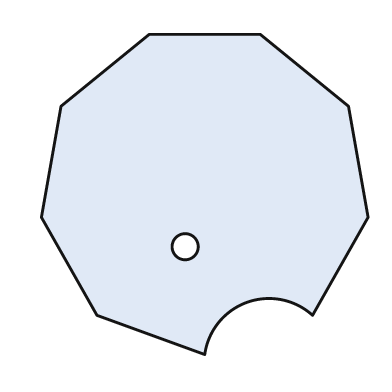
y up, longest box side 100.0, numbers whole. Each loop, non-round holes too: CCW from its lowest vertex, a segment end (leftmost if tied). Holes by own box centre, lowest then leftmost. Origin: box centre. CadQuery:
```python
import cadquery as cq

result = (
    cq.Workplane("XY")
    .moveTo(0.0, -49.0)
    .threePointArc((13.0, -33.0), (33.0, -37.0))
    .lineTo(50.0, -7.0)
    .lineTo(44.0, 27.0)
    .lineTo(17.0, 49.0)
    .lineTo(-17.0, 49.0)
    .lineTo(-44.0, 27.0)
    .lineTo(-50.0, -7.0)
    .lineTo(-33.0, -37.0)
    .close()
    .moveTo(-6.0, -16.0)
    .circle(4.0)
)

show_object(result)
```